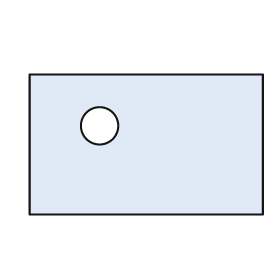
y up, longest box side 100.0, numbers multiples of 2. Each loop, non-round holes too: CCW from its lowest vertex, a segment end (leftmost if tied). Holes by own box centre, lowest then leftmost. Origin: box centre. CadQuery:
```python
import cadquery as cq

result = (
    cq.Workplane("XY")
    .moveTo(-50.0, -30.0)
    .lineTo(50.0, -30.0)
    .lineTo(50.0, 30.0)
    .lineTo(-50.0, 30.0)
    .close()
    .moveTo(-20.0, 8.0)
    .circle(8.0)
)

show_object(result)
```